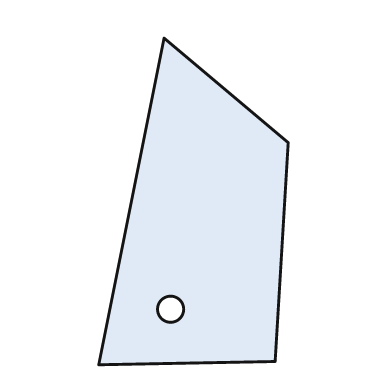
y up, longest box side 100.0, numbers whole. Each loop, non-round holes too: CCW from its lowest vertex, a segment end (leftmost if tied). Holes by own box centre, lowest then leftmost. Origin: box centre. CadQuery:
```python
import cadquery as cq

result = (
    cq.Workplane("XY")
    .moveTo(-29.0, -50.0)
    .lineTo(25.0, -49.0)
    .lineTo(29.0, 18.0)
    .lineTo(-9.0, 50.0)
    .close()
    .moveTo(-7.0, -33.0)
    .circle(4.0)
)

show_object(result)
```